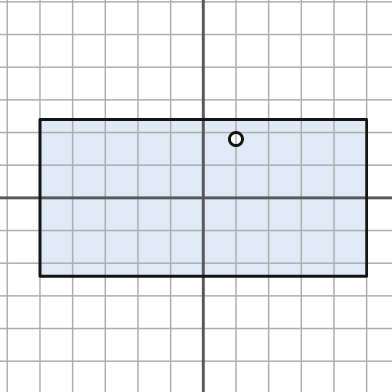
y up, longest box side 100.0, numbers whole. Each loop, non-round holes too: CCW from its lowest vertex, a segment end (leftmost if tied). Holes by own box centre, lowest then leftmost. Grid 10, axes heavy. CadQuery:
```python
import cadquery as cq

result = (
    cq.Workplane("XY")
    .moveTo(-50.0, -24.0)
    .lineTo(50.0, -24.0)
    .lineTo(50.0, 24.0)
    .lineTo(-50.0, 24.0)
    .close()
    .moveTo(10.0, 18.0)
    .circle(2.0)
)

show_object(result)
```